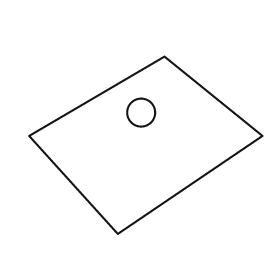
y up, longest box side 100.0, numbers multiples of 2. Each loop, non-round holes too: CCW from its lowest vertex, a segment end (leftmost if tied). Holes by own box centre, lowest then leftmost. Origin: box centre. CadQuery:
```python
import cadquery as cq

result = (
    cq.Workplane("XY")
    .moveTo(-12.0, -38.0)
    .lineTo(50.0, 4.0)
    .lineTo(8.0, 38.0)
    .lineTo(-50.0, 4.0)
    .close()
    .moveTo(-2.0, 14.0)
    .circle(6.0)
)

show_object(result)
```